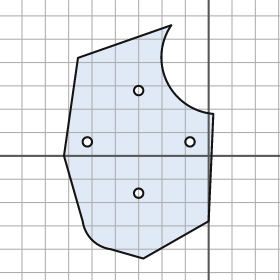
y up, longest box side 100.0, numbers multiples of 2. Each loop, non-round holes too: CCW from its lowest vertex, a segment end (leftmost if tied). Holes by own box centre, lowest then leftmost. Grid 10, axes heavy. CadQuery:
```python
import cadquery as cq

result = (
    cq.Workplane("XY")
    .moveTo(-28.0, -44.0)
    .lineTo(0.0, -28.0)
    .lineTo(2.0, 18.0)
    .threePointArc((-18.0, 32.0), (-16.0, 56.0))
    .lineTo(-56.0, 42.0)
    .lineTo(-62.0, 0.0)
    .lineTo(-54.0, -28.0)
    .threePointArc((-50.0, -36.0), (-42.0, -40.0))
    .close()
    .moveTo(-30.0, -16.0)
    .circle(2.0)
    .moveTo(-52.0, 6.0)
    .circle(2.0)
    .moveTo(-8.0, 6.0)
    .circle(2.0)
    .moveTo(-30.0, 28.0)
    .circle(2.0)
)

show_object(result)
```